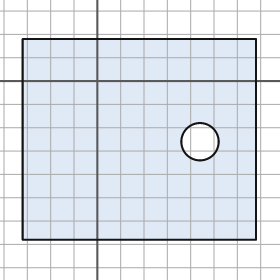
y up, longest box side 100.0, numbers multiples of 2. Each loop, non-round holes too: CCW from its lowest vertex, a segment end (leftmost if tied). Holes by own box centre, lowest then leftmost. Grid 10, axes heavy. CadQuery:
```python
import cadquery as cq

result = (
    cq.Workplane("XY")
    .moveTo(-32.0, -68.0)
    .lineTo(68.0, -68.0)
    .lineTo(68.0, 18.0)
    .lineTo(-32.0, 18.0)
    .close()
    .moveTo(44.0, -26.0)
    .circle(8.0)
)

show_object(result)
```